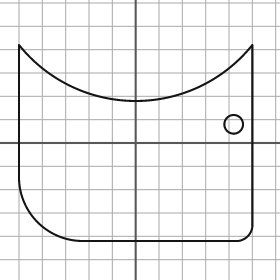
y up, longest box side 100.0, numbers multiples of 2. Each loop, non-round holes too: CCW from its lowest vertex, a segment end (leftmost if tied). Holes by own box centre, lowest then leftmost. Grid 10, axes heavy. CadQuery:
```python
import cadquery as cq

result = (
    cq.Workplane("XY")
    .moveTo(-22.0, -42.0)
    .lineTo(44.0, -42.0)
    .threePointArc((48.0, -40.0), (50.0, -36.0))
    .lineTo(50.0, 42.0)
    .threePointArc((0.0, 18.0), (-50.0, 42.0))
    .lineTo(-50.0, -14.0)
    .threePointArc((-42.0, -34.0), (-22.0, -42.0))
    .close()
    .moveTo(42.0, 8.0)
    .circle(4.0)
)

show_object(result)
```